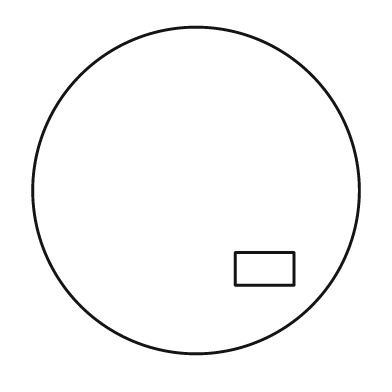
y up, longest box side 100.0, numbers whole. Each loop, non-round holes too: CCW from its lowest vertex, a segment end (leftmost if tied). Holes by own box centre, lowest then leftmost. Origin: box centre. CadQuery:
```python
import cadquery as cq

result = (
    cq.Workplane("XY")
    .moveTo(0.0, 0.0)
    .circle(50.0)
    .moveTo(12.0, -29.0)
    .lineTo(30.0, -29.0)
    .lineTo(30.0, -19.0)
    .lineTo(12.0, -19.0)
    .close()
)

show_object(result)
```